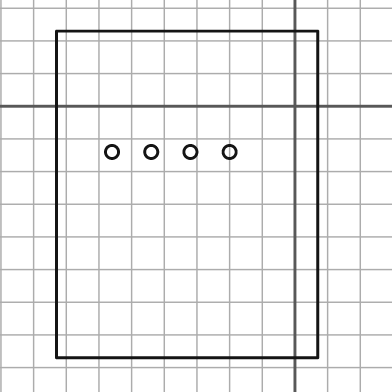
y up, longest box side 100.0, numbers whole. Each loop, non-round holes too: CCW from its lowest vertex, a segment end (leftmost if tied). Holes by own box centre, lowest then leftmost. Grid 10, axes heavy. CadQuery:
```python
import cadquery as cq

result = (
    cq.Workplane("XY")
    .moveTo(-73.0, -77.0)
    .lineTo(7.0, -77.0)
    .lineTo(7.0, 23.0)
    .lineTo(-73.0, 23.0)
    .close()
    .moveTo(-56.0, -14.0)
    .circle(2.0)
    .moveTo(-44.0, -14.0)
    .circle(2.0)
    .moveTo(-32.0, -14.0)
    .circle(2.0)
    .moveTo(-20.0, -14.0)
    .circle(2.0)
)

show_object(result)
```